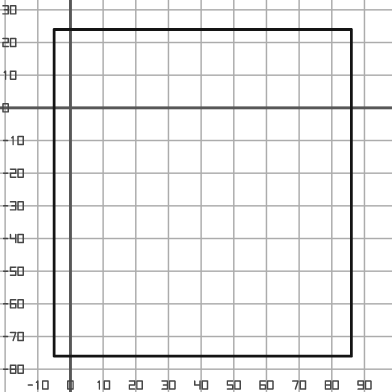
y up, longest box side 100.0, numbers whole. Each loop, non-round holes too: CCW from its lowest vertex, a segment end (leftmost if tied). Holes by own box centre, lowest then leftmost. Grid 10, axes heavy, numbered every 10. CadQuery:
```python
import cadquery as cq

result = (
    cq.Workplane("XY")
    .moveTo(-5.0, -76.0)
    .lineTo(86.0, -76.0)
    .lineTo(86.0, 24.0)
    .lineTo(-5.0, 24.0)
    .close()
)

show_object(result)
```